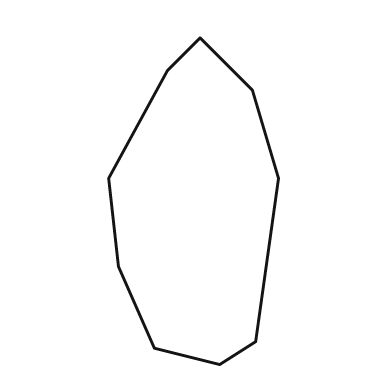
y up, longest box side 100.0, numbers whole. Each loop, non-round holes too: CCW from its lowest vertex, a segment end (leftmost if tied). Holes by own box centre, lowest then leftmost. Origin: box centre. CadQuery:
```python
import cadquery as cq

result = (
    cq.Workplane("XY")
    .moveTo(8.0, -50.0)
    .lineTo(19.0, -43.0)
    .lineTo(26.0, 7.0)
    .lineTo(18.0, 34.0)
    .lineTo(2.0, 50.0)
    .lineTo(-8.0, 40.0)
    .lineTo(-26.0, 7.0)
    .lineTo(-23.0, -20.0)
    .lineTo(-12.0, -45.0)
    .close()
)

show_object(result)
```